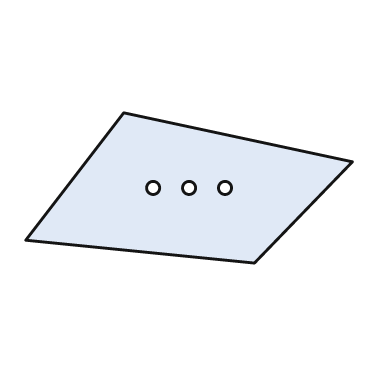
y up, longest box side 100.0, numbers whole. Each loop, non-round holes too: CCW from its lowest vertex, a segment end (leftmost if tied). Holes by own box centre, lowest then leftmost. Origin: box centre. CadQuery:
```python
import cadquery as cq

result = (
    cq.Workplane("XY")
    .moveTo(20.0, -23.0)
    .lineTo(50.0, 8.0)
    .lineTo(-20.0, 23.0)
    .lineTo(-50.0, -16.0)
    .close()
    .moveTo(-11.0, 0.0)
    .circle(2.0)
    .moveTo(0.0, 0.0)
    .circle(2.0)
    .moveTo(11.0, 0.0)
    .circle(2.0)
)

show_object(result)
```